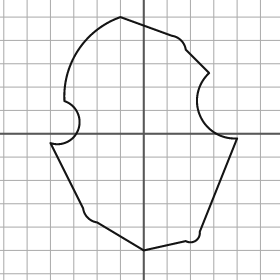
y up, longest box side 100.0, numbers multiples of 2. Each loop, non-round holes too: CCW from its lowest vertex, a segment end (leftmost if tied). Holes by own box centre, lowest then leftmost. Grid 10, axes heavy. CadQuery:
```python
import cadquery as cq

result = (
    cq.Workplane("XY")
    .moveTo(0.0, -50.0)
    .lineTo(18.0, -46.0)
    .threePointArc((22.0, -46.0), (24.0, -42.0))
    .lineTo(40.0, -2.0)
    .threePointArc((24.0, 8.0), (28.0, 26.0))
    .lineTo(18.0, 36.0)
    .threePointArc((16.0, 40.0), (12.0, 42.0))
    .lineTo(-10.0, 50.0)
    .threePointArc((-28.0, 36.0), (-34.0, 14.0))
    .threePointArc((-28.0, 2.0), (-40.0, -4.0))
    .lineTo(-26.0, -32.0)
    .threePointArc((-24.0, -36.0), (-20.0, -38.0))
    .close()
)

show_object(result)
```